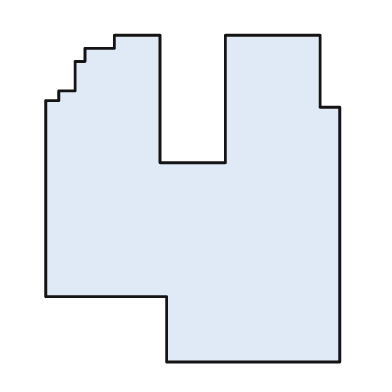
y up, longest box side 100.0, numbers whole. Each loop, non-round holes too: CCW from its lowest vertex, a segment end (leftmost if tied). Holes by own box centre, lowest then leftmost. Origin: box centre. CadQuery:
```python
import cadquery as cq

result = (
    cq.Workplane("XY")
    .moveTo(-8.0, -50.0)
    .lineTo(45.0, -50.0)
    .lineTo(45.0, 28.0)
    .lineTo(39.0, 28.0)
    .lineTo(39.0, 50.0)
    .lineTo(10.0, 50.0)
    .lineTo(10.0, 11.0)
    .lineTo(-10.0, 11.0)
    .lineTo(-10.0, 50.0)
    .lineTo(-24.0, 50.0)
    .lineTo(-24.0, 46.0)
    .lineTo(-33.0, 46.0)
    .lineTo(-33.0, 42.0)
    .lineTo(-36.0, 42.0)
    .lineTo(-36.0, 33.0)
    .lineTo(-41.0, 33.0)
    .lineTo(-41.0, 30.0)
    .lineTo(-45.0, 30.0)
    .lineTo(-45.0, -30.0)
    .lineTo(-8.0, -30.0)
    .close()
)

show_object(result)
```